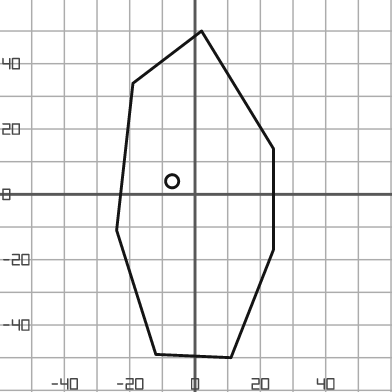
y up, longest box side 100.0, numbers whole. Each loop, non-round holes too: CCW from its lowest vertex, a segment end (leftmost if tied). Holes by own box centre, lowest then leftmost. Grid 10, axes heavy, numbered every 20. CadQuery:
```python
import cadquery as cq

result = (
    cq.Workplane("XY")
    .moveTo(11.0, -50.0)
    .lineTo(24.0, -17.0)
    .lineTo(24.0, 14.0)
    .lineTo(2.0, 50.0)
    .lineTo(-19.0, 34.0)
    .lineTo(-24.0, -11.0)
    .lineTo(-12.0, -49.0)
    .close()
    .moveTo(-7.0, 4.0)
    .circle(2.0)
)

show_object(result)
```